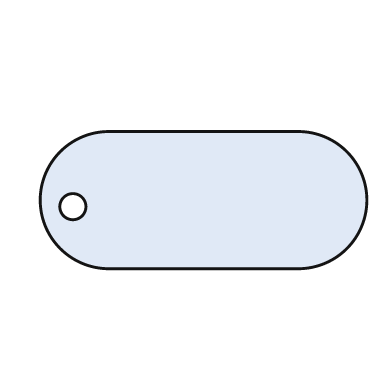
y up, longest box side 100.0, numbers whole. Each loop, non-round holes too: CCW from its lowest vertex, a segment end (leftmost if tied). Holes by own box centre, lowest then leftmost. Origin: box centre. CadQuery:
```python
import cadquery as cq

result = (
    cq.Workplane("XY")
    .moveTo(-29.0, -21.0)
    .lineTo(29.0, -21.0)
    .threePointArc((50.0, 0.0), (29.0, 21.0))
    .lineTo(-29.0, 21.0)
    .threePointArc((-50.0, 0.0), (-29.0, -21.0))
    .close()
    .moveTo(-40.0, -2.0)
    .circle(4.0)
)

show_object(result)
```